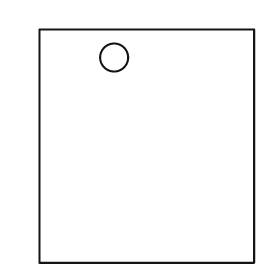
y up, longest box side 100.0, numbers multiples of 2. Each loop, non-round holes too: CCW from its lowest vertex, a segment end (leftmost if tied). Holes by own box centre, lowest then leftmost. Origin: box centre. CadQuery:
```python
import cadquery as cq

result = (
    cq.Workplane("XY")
    .moveTo(-46.0, -50.0)
    .lineTo(46.0, -50.0)
    .lineTo(46.0, 50.0)
    .lineTo(-46.0, 50.0)
    .close()
    .moveTo(-14.0, 38.0)
    .circle(6.0)
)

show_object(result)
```